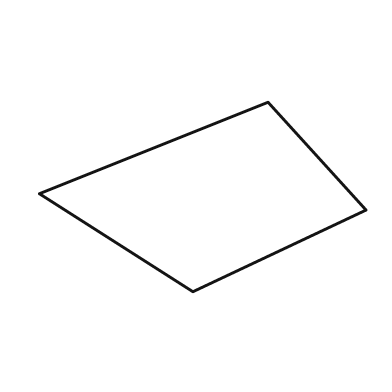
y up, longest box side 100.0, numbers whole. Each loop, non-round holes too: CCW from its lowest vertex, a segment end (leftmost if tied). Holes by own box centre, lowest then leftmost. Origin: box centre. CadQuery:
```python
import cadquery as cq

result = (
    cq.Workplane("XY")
    .moveTo(-3.0, -29.0)
    .lineTo(50.0, -4.0)
    .lineTo(20.0, 29.0)
    .lineTo(-50.0, 1.0)
    .close()
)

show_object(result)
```